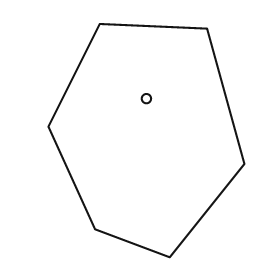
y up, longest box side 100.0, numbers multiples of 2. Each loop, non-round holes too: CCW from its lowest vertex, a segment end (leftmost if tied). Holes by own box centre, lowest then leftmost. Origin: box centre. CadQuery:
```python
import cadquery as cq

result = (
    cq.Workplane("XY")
    .moveTo(10.0, -50.0)
    .lineTo(42.0, -10.0)
    .lineTo(26.0, 48.0)
    .lineTo(-20.0, 50.0)
    .lineTo(-42.0, 6.0)
    .lineTo(-22.0, -38.0)
    .close()
    .moveTo(0.0, 18.0)
    .circle(2.0)
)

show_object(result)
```